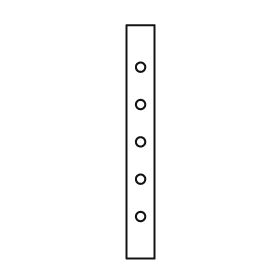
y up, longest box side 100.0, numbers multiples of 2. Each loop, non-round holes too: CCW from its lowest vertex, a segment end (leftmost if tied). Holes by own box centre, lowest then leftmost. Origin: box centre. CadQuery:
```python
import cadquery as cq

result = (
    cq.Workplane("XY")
    .moveTo(-6.0, -50.0)
    .lineTo(6.0, -50.0)
    .lineTo(6.0, 50.0)
    .lineTo(-6.0, 50.0)
    .close()
    .moveTo(0.0, -32.0)
    .circle(2.0)
    .moveTo(0.0, -16.0)
    .circle(2.0)
    .moveTo(0.0, 0.0)
    .circle(2.0)
    .moveTo(0.0, 16.0)
    .circle(2.0)
    .moveTo(0.0, 32.0)
    .circle(2.0)
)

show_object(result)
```